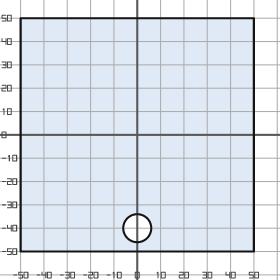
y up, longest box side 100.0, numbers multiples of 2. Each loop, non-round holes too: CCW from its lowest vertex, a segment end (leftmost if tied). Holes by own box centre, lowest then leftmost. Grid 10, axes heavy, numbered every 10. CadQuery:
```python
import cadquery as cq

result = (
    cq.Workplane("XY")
    .moveTo(-50.0, -50.0)
    .lineTo(50.0, -50.0)
    .lineTo(50.0, 50.0)
    .lineTo(-50.0, 50.0)
    .close()
    .moveTo(0.0, -40.0)
    .circle(6.0)
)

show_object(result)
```